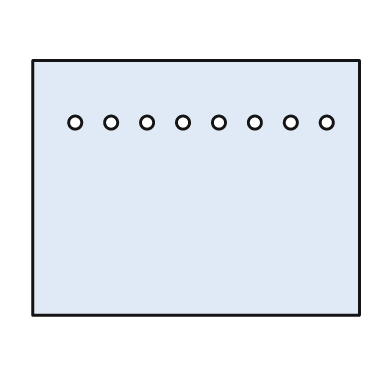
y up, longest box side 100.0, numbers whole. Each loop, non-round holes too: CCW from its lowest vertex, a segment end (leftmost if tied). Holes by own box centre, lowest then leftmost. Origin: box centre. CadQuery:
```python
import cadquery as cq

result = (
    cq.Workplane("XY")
    .moveTo(-50.0, -39.0)
    .lineTo(50.0, -39.0)
    .lineTo(50.0, 39.0)
    .lineTo(-50.0, 39.0)
    .close()
    .moveTo(-37.0, 20.0)
    .circle(2.0)
    .moveTo(-26.0, 20.0)
    .circle(2.0)
    .moveTo(-15.0, 20.0)
    .circle(2.0)
    .moveTo(-4.0, 20.0)
    .circle(2.0)
    .moveTo(7.0, 20.0)
    .circle(2.0)
    .moveTo(18.0, 20.0)
    .circle(2.0)
    .moveTo(29.0, 20.0)
    .circle(2.0)
    .moveTo(40.0, 20.0)
    .circle(2.0)
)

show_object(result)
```